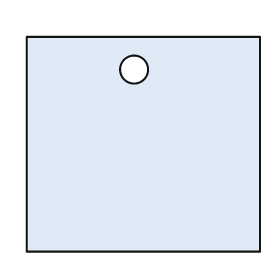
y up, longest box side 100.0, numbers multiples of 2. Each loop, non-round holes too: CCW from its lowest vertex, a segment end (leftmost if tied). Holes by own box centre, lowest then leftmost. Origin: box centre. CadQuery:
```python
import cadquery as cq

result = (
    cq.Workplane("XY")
    .moveTo(-50.0, -46.0)
    .lineTo(50.0, -46.0)
    .lineTo(50.0, 46.0)
    .lineTo(-50.0, 46.0)
    .close()
    .moveTo(-4.0, 32.0)
    .circle(6.0)
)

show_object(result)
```